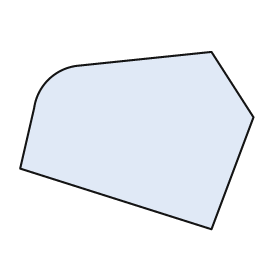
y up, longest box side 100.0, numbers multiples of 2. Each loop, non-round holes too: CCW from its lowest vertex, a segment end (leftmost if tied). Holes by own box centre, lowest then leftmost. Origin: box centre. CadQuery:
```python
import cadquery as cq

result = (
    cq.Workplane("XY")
    .moveTo(32.0, -38.0)
    .lineTo(50.0, 10.0)
    .lineTo(32.0, 38.0)
    .lineTo(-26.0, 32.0)
    .threePointArc((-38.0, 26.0), (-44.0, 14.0))
    .lineTo(-50.0, -12.0)
    .close()
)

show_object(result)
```